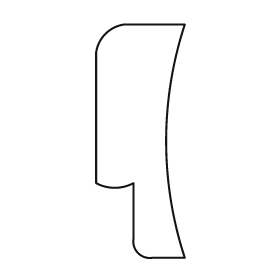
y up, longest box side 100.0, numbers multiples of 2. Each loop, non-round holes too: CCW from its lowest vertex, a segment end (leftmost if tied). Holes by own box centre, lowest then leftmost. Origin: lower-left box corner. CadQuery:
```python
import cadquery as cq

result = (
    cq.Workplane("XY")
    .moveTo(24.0, 0.0)
    .lineTo(38.0, 0.0)
    .threePointArc((30.0, 50.0), (38.0, 100.0))
    .lineTo(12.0, 100.0)
    .threePointArc((4.0, 96.0), (0.0, 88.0))
    .lineTo(0.0, 32.0)
    .threePointArc((8.0, 30.0), (16.0, 32.0))
    .lineTo(16.0, 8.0)
    .threePointArc((18.0, 2.0), (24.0, 0.0))
    .close()
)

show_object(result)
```